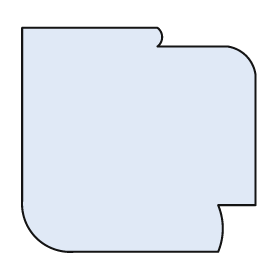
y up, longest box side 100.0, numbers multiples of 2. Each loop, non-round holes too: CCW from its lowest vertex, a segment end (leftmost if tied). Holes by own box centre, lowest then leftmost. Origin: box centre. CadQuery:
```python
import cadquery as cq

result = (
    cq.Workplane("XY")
    .moveTo(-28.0, -48.0)
    .lineTo(34.0, -48.0)
    .threePointArc((36.0, -38.0), (34.0, -28.0))
    .lineTo(50.0, -28.0)
    .lineTo(50.0, 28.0)
    .threePointArc((46.0, 36.0), (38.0, 40.0))
    .lineTo(8.0, 40.0)
    .threePointArc((10.0, 44.0), (8.0, 48.0))
    .lineTo(-50.0, 48.0)
    .lineTo(-50.0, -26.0)
    .threePointArc((-44.0, -42.0), (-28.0, -48.0))
    .close()
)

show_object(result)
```